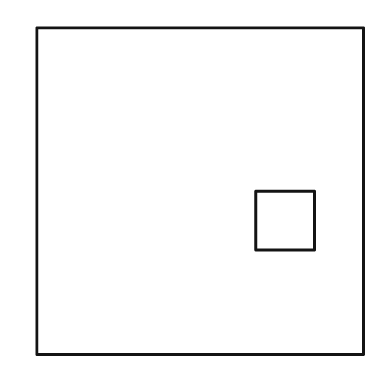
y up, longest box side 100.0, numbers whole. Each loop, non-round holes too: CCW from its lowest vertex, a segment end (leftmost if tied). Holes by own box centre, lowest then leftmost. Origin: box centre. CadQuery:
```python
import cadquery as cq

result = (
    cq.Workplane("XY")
    .moveTo(-50.0, -50.0)
    .lineTo(50.0, -50.0)
    .lineTo(50.0, 50.0)
    .lineTo(-50.0, 50.0)
    .close()
    .moveTo(17.0, -18.0)
    .lineTo(35.0, -18.0)
    .lineTo(35.0, 0.0)
    .lineTo(17.0, 0.0)
    .close()
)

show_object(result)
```